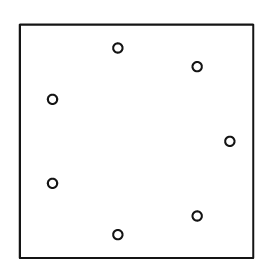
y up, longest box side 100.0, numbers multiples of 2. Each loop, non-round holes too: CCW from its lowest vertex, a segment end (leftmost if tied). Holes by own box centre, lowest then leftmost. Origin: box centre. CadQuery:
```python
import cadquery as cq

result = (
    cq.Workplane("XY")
    .moveTo(-50.0, -50.0)
    .lineTo(50.0, -50.0)
    .lineTo(50.0, 50.0)
    .lineTo(-50.0, 50.0)
    .close()
    .moveTo(-8.0, -40.0)
    .circle(2.0)
    .moveTo(26.0, -32.0)
    .circle(2.0)
    .moveTo(-36.0, -18.0)
    .circle(2.0)
    .moveTo(40.0, 0.0)
    .circle(2.0)
    .moveTo(-36.0, 18.0)
    .circle(2.0)
    .moveTo(26.0, 32.0)
    .circle(2.0)
    .moveTo(-8.0, 40.0)
    .circle(2.0)
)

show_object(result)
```